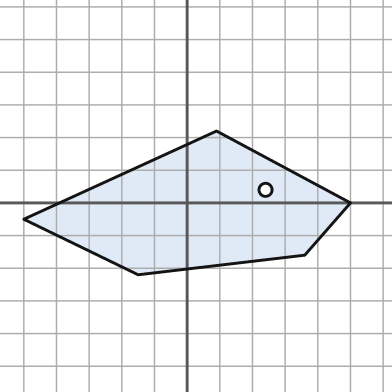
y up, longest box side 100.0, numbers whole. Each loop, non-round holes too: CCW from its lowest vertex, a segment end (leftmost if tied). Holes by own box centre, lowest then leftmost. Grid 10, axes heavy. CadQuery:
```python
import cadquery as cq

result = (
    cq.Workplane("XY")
    .moveTo(-15.0, -22.0)
    .lineTo(36.0, -16.0)
    .lineTo(50.0, 0.0)
    .lineTo(9.0, 22.0)
    .lineTo(-50.0, -5.0)
    .close()
    .moveTo(24.0, 4.0)
    .circle(2.0)
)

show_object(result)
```